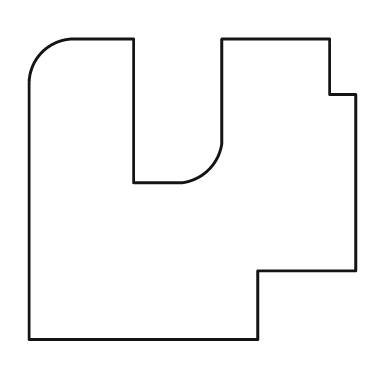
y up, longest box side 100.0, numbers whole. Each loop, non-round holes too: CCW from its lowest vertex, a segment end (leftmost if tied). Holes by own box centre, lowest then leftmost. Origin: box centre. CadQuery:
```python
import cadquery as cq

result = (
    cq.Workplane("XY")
    .moveTo(-50.0, -46.0)
    .lineTo(20.0, -46.0)
    .lineTo(20.0, -25.0)
    .lineTo(50.0, -25.0)
    .lineTo(50.0, 29.0)
    .lineTo(42.0, 29.0)
    .lineTo(42.0, 46.0)
    .lineTo(9.0, 46.0)
    .lineTo(9.0, 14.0)
    .threePointArc((5.0, 6.0), (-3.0, 2.0))
    .lineTo(-18.0, 2.0)
    .lineTo(-18.0, 46.0)
    .lineTo(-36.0, 46.0)
    .threePointArc((-46.0, 42.0), (-50.0, 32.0))
    .close()
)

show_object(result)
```